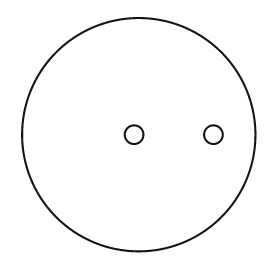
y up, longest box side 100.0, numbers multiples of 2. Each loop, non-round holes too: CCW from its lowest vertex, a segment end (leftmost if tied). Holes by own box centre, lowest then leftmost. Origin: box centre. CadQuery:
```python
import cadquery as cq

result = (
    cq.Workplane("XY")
    .moveTo(0.0, 0.0)
    .circle(50.0)
    .moveTo(-2.0, 0.0)
    .circle(4.0)
    .moveTo(32.0, 0.0)
    .circle(4.0)
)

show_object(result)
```